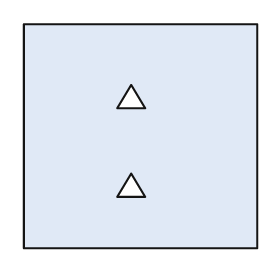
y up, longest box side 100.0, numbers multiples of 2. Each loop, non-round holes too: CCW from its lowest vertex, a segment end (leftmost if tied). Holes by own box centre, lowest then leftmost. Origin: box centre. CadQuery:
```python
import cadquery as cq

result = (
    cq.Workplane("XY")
    .moveTo(-50.0, -48.0)
    .lineTo(50.0, -48.0)
    .lineTo(50.0, 48.0)
    .lineTo(-50.0, 48.0)
    .close()
    .moveTo(-10.0, -26.0)
    .lineTo(2.0, -26.0)
    .lineTo(-4.0, -16.0)
    .close()
    .moveTo(-10.0, 12.0)
    .lineTo(2.0, 12.0)
    .lineTo(-4.0, 22.0)
    .close()
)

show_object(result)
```